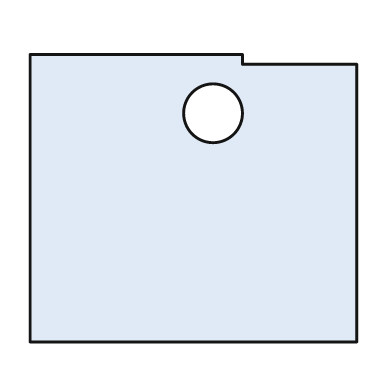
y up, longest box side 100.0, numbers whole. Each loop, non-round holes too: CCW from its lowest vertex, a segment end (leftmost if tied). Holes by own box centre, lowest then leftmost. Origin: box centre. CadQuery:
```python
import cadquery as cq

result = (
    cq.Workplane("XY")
    .moveTo(-50.0, -44.0)
    .lineTo(50.0, -44.0)
    .lineTo(50.0, 41.0)
    .lineTo(15.0, 41.0)
    .lineTo(15.0, 44.0)
    .lineTo(-50.0, 44.0)
    .close()
    .moveTo(6.0, 26.0)
    .circle(9.0)
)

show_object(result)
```